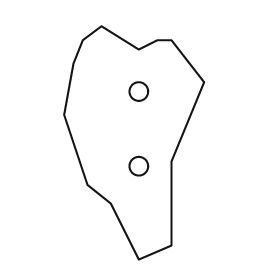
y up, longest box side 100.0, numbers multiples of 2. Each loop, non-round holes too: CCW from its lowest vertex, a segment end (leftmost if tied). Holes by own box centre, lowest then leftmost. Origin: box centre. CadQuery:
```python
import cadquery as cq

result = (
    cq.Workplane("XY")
    .moveTo(2.0, -50.0)
    .lineTo(16.0, -44.0)
    .lineTo(16.0, -8.0)
    .lineTo(30.0, 26.0)
    .lineTo(16.0, 44.0)
    .lineTo(10.0, 44.0)
    .lineTo(2.0, 40.0)
    .lineTo(-14.0, 50.0)
    .lineTo(-22.0, 44.0)
    .lineTo(-26.0, 34.0)
    .lineTo(-30.0, 12.0)
    .lineTo(-20.0, -18.0)
    .lineTo(-10.0, -26.0)
    .close()
    .moveTo(2.0, -10.0)
    .circle(4.0)
    .moveTo(2.0, 22.0)
    .circle(4.0)
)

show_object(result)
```